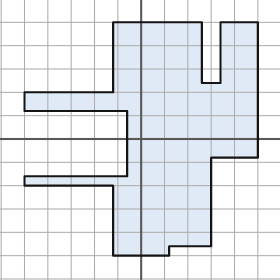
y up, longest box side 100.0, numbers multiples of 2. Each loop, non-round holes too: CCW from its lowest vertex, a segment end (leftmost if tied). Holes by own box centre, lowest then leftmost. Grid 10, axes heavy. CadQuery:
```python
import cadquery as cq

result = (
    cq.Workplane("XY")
    .moveTo(-12.0, -50.0)
    .lineTo(12.0, -50.0)
    .lineTo(12.0, -46.0)
    .lineTo(30.0, -46.0)
    .lineTo(30.0, -8.0)
    .lineTo(50.0, -8.0)
    .lineTo(50.0, 50.0)
    .lineTo(34.0, 50.0)
    .lineTo(34.0, 24.0)
    .lineTo(26.0, 24.0)
    .lineTo(26.0, 50.0)
    .lineTo(-12.0, 50.0)
    .lineTo(-12.0, 20.0)
    .lineTo(-50.0, 20.0)
    .lineTo(-50.0, 12.0)
    .lineTo(-6.0, 12.0)
    .lineTo(-6.0, -16.0)
    .lineTo(-50.0, -16.0)
    .lineTo(-50.0, -20.0)
    .lineTo(-12.0, -20.0)
    .close()
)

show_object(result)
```